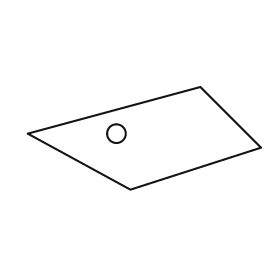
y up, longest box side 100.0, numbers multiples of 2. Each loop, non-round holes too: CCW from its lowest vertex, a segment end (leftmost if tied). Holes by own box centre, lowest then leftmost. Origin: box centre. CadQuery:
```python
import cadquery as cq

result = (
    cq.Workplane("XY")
    .moveTo(-6.0, -22.0)
    .lineTo(50.0, -4.0)
    .lineTo(24.0, 22.0)
    .lineTo(-50.0, 2.0)
    .close()
    .moveTo(-12.0, 2.0)
    .circle(4.0)
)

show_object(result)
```